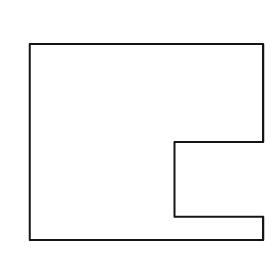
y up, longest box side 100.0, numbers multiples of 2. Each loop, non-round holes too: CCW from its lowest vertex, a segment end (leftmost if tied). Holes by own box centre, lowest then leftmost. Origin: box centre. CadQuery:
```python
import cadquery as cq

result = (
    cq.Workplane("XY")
    .moveTo(-50.0, -42.0)
    .lineTo(50.0, -42.0)
    .lineTo(50.0, -32.0)
    .lineTo(12.0, -32.0)
    .lineTo(12.0, 0.0)
    .lineTo(50.0, 0.0)
    .lineTo(50.0, 42.0)
    .lineTo(-50.0, 42.0)
    .close()
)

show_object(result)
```